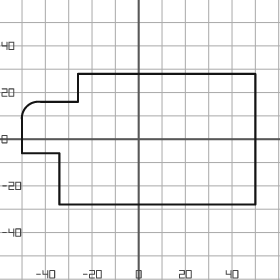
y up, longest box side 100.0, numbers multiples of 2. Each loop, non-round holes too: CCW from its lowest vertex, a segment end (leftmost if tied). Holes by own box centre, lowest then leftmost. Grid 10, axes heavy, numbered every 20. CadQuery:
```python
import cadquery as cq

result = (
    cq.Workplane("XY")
    .moveTo(-34.0, -28.0)
    .lineTo(50.0, -28.0)
    .lineTo(50.0, 28.0)
    .lineTo(-26.0, 28.0)
    .lineTo(-26.0, 16.0)
    .lineTo(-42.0, 16.0)
    .threePointArc((-48.0, 14.0), (-50.0, 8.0))
    .lineTo(-50.0, -6.0)
    .lineTo(-34.0, -6.0)
    .close()
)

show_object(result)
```